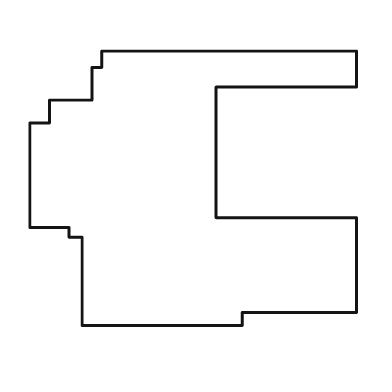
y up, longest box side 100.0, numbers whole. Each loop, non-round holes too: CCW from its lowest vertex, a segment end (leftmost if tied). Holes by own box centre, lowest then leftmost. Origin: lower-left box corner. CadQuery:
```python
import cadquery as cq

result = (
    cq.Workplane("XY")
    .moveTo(16.0, 0.0)
    .lineTo(65.0, 0.0)
    .lineTo(65.0, 4.0)
    .lineTo(100.0, 4.0)
    .lineTo(100.0, 33.0)
    .lineTo(57.0, 33.0)
    .lineTo(57.0, 73.0)
    .lineTo(100.0, 73.0)
    .lineTo(100.0, 84.0)
    .lineTo(22.0, 84.0)
    .lineTo(22.0, 79.0)
    .lineTo(19.0, 79.0)
    .lineTo(19.0, 69.0)
    .lineTo(6.0, 69.0)
    .lineTo(6.0, 62.0)
    .lineTo(0.0, 62.0)
    .lineTo(0.0, 30.0)
    .lineTo(12.0, 30.0)
    .lineTo(12.0, 27.0)
    .lineTo(16.0, 27.0)
    .close()
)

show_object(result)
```